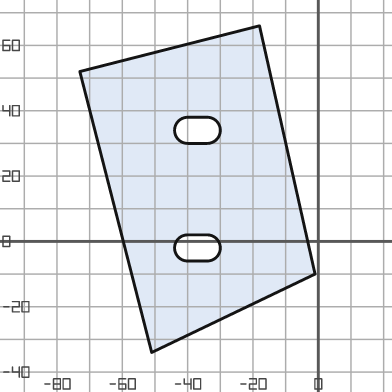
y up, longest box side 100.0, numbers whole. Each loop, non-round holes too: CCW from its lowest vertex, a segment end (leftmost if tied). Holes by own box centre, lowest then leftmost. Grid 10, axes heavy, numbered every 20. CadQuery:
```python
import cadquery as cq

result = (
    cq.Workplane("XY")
    .moveTo(-51.0, -34.0)
    .lineTo(-1.0, -10.0)
    .lineTo(-18.0, 66.0)
    .lineTo(-73.0, 52.0)
    .close()
    .moveTo(-40.0, -6.0)
    .lineTo(-34.0, -6.0)
    .threePointArc((-30.0, -2.0), (-34.0, 2.0))
    .lineTo(-40.0, 2.0)
    .threePointArc((-44.0, -2.0), (-40.0, -6.0))
    .close()
    .moveTo(-40.0, 30.0)
    .lineTo(-34.0, 30.0)
    .threePointArc((-30.0, 34.0), (-34.0, 38.0))
    .lineTo(-40.0, 38.0)
    .threePointArc((-44.0, 34.0), (-40.0, 30.0))
    .close()
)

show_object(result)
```